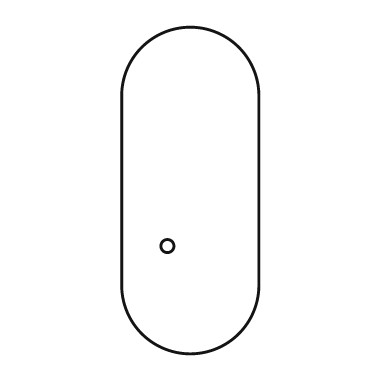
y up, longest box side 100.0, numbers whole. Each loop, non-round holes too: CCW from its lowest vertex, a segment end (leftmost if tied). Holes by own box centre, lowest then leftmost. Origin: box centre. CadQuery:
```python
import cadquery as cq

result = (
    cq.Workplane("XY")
    .moveTo(-21.0, -29.0)
    .threePointArc((0.0, -50.0), (21.0, -29.0))
    .lineTo(21.0, 29.0)
    .threePointArc((0.0, 50.0), (-21.0, 29.0))
    .close()
    .moveTo(-7.0, -17.0)
    .circle(2.0)
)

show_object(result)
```